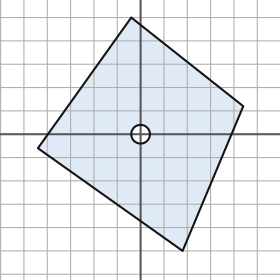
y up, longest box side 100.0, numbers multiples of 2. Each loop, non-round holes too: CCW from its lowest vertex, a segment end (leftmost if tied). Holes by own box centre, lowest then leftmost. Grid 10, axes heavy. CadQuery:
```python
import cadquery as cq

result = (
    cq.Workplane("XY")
    .moveTo(18.0, -50.0)
    .lineTo(44.0, 12.0)
    .lineTo(-4.0, 50.0)
    .lineTo(-44.0, -6.0)
    .close()
    .moveTo(0.0, 0.0)
    .circle(4.0)
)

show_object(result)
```